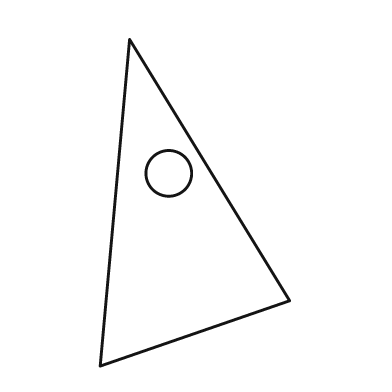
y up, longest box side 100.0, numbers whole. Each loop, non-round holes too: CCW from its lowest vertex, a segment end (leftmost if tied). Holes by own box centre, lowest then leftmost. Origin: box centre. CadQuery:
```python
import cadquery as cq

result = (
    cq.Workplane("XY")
    .moveTo(-29.0, -50.0)
    .lineTo(29.0, -30.0)
    .lineTo(-20.0, 50.0)
    .close()
    .moveTo(-8.0, 9.0)
    .circle(7.0)
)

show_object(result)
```